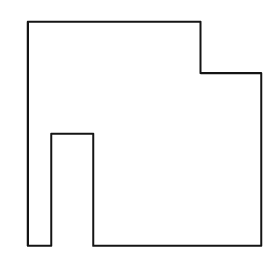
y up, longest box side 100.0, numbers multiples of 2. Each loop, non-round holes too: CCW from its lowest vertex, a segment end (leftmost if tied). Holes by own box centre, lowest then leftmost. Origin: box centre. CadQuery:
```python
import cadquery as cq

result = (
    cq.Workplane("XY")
    .moveTo(-50.0, -48.0)
    .lineTo(-40.0, -48.0)
    .lineTo(-40.0, 0.0)
    .lineTo(-22.0, 0.0)
    .lineTo(-22.0, -48.0)
    .lineTo(50.0, -48.0)
    .lineTo(50.0, 26.0)
    .lineTo(24.0, 26.0)
    .lineTo(24.0, 48.0)
    .lineTo(-50.0, 48.0)
    .close()
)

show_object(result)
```